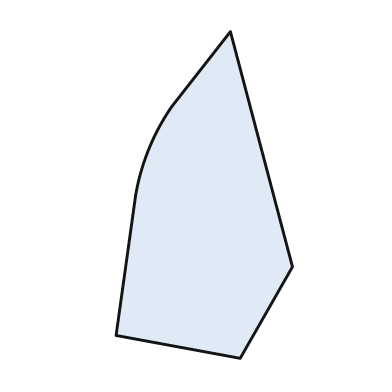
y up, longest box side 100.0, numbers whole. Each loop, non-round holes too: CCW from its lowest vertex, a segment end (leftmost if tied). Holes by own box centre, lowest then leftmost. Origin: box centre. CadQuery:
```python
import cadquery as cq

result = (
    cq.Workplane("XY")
    .moveTo(11.0, -50.0)
    .lineTo(27.0, -22.0)
    .lineTo(8.0, 50.0)
    .lineTo(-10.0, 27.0)
    .threePointArc((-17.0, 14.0), (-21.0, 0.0))
    .lineTo(-27.0, -43.0)
    .close()
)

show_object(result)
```